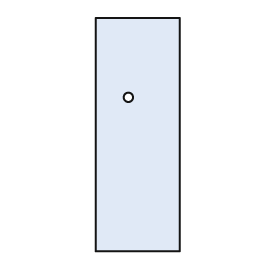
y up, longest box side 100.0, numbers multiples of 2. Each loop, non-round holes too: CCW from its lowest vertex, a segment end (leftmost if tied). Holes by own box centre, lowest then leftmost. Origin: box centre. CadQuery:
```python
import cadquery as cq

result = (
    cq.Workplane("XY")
    .moveTo(-18.0, -50.0)
    .lineTo(18.0, -50.0)
    .lineTo(18.0, 50.0)
    .lineTo(-18.0, 50.0)
    .close()
    .moveTo(-4.0, 16.0)
    .circle(2.0)
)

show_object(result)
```